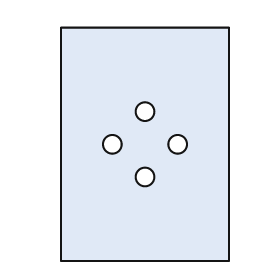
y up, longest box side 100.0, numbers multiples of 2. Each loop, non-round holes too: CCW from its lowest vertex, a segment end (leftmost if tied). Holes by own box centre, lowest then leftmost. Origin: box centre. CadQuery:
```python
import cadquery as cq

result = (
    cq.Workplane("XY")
    .moveTo(-36.0, -50.0)
    .lineTo(36.0, -50.0)
    .lineTo(36.0, 50.0)
    .lineTo(-36.0, 50.0)
    .close()
    .moveTo(0.0, -14.0)
    .circle(4.0)
    .moveTo(-14.0, 0.0)
    .circle(4.0)
    .moveTo(14.0, 0.0)
    .circle(4.0)
    .moveTo(0.0, 14.0)
    .circle(4.0)
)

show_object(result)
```